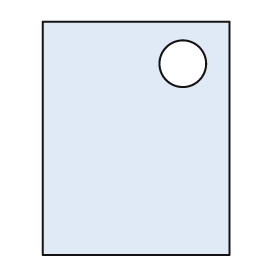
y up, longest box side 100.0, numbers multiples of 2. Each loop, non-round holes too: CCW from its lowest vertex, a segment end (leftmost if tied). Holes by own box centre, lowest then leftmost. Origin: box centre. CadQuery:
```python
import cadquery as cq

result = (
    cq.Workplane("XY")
    .moveTo(-40.0, -50.0)
    .lineTo(40.0, -50.0)
    .lineTo(40.0, 50.0)
    .lineTo(-40.0, 50.0)
    .close()
    .moveTo(20.0, 32.0)
    .circle(10.0)
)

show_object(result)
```